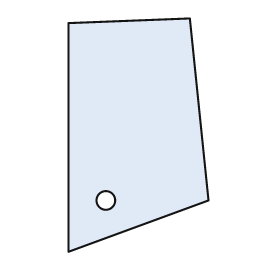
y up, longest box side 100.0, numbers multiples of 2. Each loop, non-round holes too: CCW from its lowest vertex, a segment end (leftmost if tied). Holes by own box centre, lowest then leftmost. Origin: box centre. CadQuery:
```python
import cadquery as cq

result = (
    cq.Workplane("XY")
    .moveTo(-30.0, -50.0)
    .lineTo(30.0, -28.0)
    .lineTo(22.0, 50.0)
    .lineTo(-30.0, 48.0)
    .close()
    .moveTo(-14.0, -28.0)
    .circle(4.0)
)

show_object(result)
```